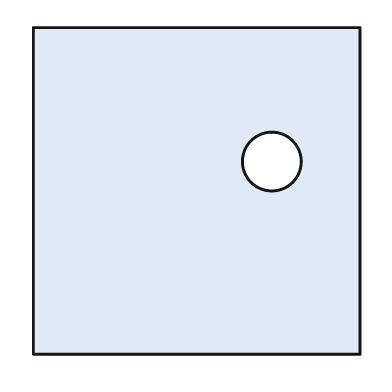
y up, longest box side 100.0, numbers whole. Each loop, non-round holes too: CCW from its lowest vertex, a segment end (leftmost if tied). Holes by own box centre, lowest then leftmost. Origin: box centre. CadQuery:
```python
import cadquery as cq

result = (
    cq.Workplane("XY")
    .moveTo(-50.0, -50.0)
    .lineTo(50.0, -50.0)
    .lineTo(50.0, 50.0)
    .lineTo(-50.0, 50.0)
    .close()
    .moveTo(23.0, 9.0)
    .circle(9.0)
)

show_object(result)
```